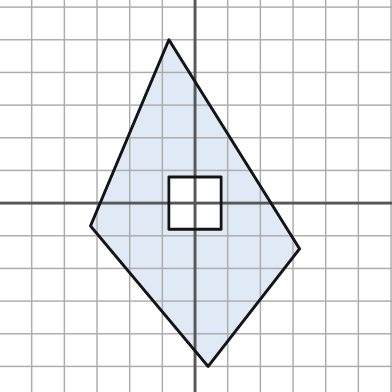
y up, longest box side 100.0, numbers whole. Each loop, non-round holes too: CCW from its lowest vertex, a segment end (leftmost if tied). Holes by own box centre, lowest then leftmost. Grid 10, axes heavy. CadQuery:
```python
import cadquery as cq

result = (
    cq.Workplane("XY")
    .moveTo(4.0, -50.0)
    .lineTo(32.0, -14.0)
    .lineTo(-8.0, 50.0)
    .lineTo(-32.0, -7.0)
    .close()
    .moveTo(-8.0, -8.0)
    .lineTo(8.0, -8.0)
    .lineTo(8.0, 8.0)
    .lineTo(-8.0, 8.0)
    .close()
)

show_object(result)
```